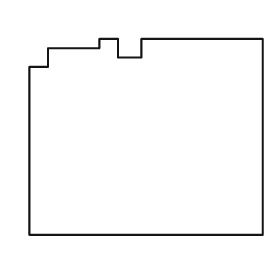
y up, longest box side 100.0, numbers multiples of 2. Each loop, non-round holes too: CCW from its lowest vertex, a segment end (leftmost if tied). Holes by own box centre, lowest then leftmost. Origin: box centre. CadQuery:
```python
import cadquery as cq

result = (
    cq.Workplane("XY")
    .moveTo(-50.0, -42.0)
    .lineTo(50.0, -42.0)
    .lineTo(50.0, 42.0)
    .lineTo(-2.0, 42.0)
    .lineTo(-2.0, 34.0)
    .lineTo(-12.0, 34.0)
    .lineTo(-12.0, 42.0)
    .lineTo(-20.0, 42.0)
    .lineTo(-20.0, 38.0)
    .lineTo(-42.0, 38.0)
    .lineTo(-42.0, 30.0)
    .lineTo(-50.0, 30.0)
    .close()
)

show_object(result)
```